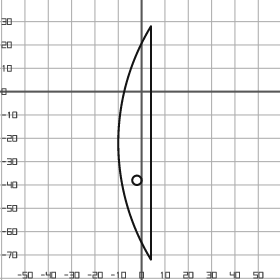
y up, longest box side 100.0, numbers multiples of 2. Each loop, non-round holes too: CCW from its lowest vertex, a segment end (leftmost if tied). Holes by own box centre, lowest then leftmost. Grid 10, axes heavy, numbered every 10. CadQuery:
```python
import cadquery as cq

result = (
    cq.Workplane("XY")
    .moveTo(4.0, -72.0)
    .lineTo(4.0, 28.0)
    .threePointArc((-10.0, -22.0), (4.0, -72.0))
    .close()
    .moveTo(-2.0, -38.0)
    .circle(2.0)
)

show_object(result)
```